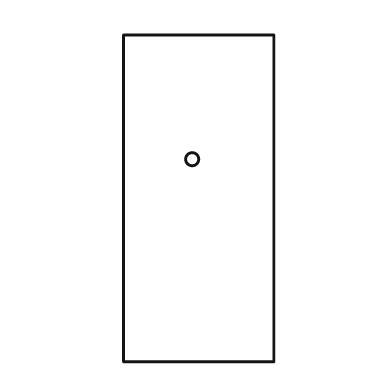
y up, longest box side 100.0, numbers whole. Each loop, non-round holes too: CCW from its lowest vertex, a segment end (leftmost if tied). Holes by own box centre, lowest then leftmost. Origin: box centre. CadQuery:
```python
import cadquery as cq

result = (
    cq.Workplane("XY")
    .moveTo(-23.0, -50.0)
    .lineTo(23.0, -50.0)
    .lineTo(23.0, 50.0)
    .lineTo(-23.0, 50.0)
    .close()
    .moveTo(-2.0, 12.0)
    .circle(2.0)
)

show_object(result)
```